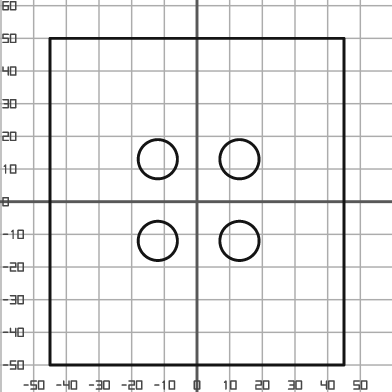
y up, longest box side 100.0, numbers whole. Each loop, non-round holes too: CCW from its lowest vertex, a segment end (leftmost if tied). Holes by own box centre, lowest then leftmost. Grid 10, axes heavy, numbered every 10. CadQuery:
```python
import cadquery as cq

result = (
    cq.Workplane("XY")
    .moveTo(-45.0, -50.0)
    .lineTo(45.0, -50.0)
    .lineTo(45.0, 50.0)
    .lineTo(-45.0, 50.0)
    .close()
    .moveTo(-12.0, -12.0)
    .circle(6.0)
    .moveTo(13.0, -12.0)
    .circle(6.0)
    .moveTo(-12.0, 13.0)
    .circle(6.0)
    .moveTo(13.0, 13.0)
    .circle(6.0)
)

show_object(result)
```